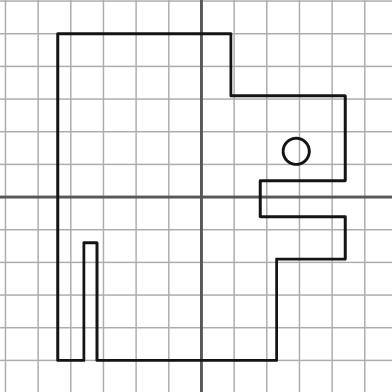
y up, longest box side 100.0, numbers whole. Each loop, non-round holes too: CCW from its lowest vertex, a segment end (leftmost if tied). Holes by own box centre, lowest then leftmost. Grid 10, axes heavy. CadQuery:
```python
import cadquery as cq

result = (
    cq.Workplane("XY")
    .moveTo(-44.0, -50.0)
    .lineTo(-36.0, -50.0)
    .lineTo(-36.0, -14.0)
    .lineTo(-32.0, -14.0)
    .lineTo(-32.0, -50.0)
    .lineTo(23.0, -50.0)
    .lineTo(23.0, -19.0)
    .lineTo(44.0, -19.0)
    .lineTo(44.0, -6.0)
    .lineTo(18.0, -6.0)
    .lineTo(18.0, 5.0)
    .lineTo(44.0, 5.0)
    .lineTo(44.0, 31.0)
    .lineTo(9.0, 31.0)
    .lineTo(9.0, 50.0)
    .lineTo(-44.0, 50.0)
    .close()
    .moveTo(29.0, 14.0)
    .circle(4.0)
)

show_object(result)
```